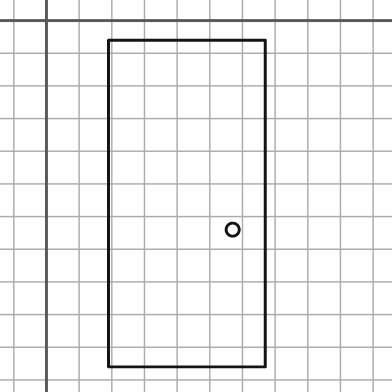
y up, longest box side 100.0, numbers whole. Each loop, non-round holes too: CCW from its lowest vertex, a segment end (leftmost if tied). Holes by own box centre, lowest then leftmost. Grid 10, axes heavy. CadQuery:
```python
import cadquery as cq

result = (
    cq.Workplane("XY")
    .moveTo(19.0, -106.0)
    .lineTo(67.0, -106.0)
    .lineTo(67.0, -6.0)
    .lineTo(19.0, -6.0)
    .close()
    .moveTo(57.0, -64.0)
    .circle(2.0)
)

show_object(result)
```